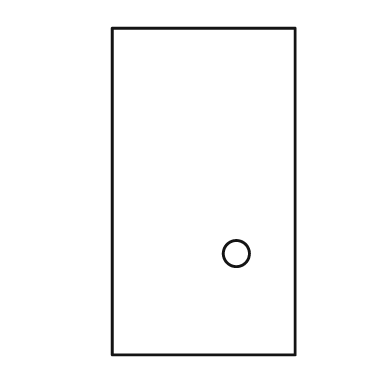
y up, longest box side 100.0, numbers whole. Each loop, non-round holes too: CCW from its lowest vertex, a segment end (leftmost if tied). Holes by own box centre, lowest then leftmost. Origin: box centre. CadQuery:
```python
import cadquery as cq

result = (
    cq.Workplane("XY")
    .moveTo(-28.0, -50.0)
    .lineTo(28.0, -50.0)
    .lineTo(28.0, 50.0)
    .lineTo(-28.0, 50.0)
    .close()
    .moveTo(10.0, -19.0)
    .circle(4.0)
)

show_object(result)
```